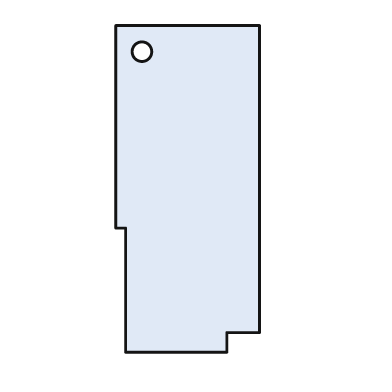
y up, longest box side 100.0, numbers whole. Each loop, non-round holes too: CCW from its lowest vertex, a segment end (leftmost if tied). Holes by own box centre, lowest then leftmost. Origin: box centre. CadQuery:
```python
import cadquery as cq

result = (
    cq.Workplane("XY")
    .moveTo(-19.0, -50.0)
    .lineTo(12.0, -50.0)
    .lineTo(12.0, -44.0)
    .lineTo(22.0, -44.0)
    .lineTo(22.0, 50.0)
    .lineTo(-22.0, 50.0)
    .lineTo(-22.0, -12.0)
    .lineTo(-19.0, -12.0)
    .close()
    .moveTo(-14.0, 42.0)
    .circle(3.0)
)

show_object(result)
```